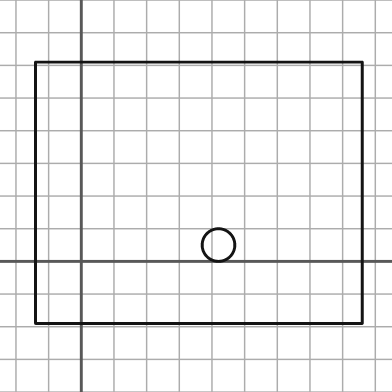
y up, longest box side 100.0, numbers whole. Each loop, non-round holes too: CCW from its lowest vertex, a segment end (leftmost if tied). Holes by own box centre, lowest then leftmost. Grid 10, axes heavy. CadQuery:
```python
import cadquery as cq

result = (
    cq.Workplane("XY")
    .moveTo(-14.0, -19.0)
    .lineTo(86.0, -19.0)
    .lineTo(86.0, 61.0)
    .lineTo(-14.0, 61.0)
    .close()
    .moveTo(42.0, 5.0)
    .circle(5.0)
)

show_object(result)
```